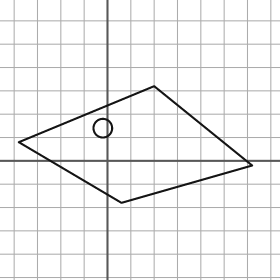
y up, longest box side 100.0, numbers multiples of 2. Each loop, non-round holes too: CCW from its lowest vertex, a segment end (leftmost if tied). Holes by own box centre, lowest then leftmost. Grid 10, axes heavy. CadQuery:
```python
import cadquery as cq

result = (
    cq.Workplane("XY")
    .moveTo(6.0, -18.0)
    .lineTo(62.0, -2.0)
    .lineTo(20.0, 32.0)
    .lineTo(-38.0, 8.0)
    .close()
    .moveTo(-2.0, 14.0)
    .circle(4.0)
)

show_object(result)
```